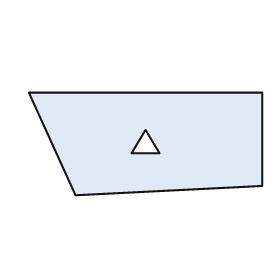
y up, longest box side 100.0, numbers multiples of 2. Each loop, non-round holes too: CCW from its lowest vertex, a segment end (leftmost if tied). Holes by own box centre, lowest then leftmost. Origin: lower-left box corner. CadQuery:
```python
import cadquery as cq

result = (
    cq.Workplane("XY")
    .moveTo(20.0, 0.0)
    .lineTo(100.0, 4.0)
    .lineTo(100.0, 44.0)
    .lineTo(0.0, 44.0)
    .close()
    .moveTo(44.0, 18.0)
    .lineTo(56.0, 18.0)
    .lineTo(50.0, 28.0)
    .close()
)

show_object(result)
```